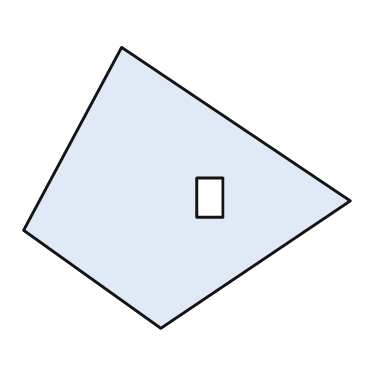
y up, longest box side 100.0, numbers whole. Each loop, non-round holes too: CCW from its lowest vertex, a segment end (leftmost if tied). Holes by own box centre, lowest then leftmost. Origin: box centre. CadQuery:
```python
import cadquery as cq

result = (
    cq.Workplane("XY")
    .moveTo(-8.0, -43.0)
    .lineTo(50.0, -4.0)
    .lineTo(-20.0, 43.0)
    .lineTo(-50.0, -13.0)
    .close()
    .moveTo(3.0, -9.0)
    .lineTo(11.0, -9.0)
    .lineTo(11.0, 3.0)
    .lineTo(3.0, 3.0)
    .close()
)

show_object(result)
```